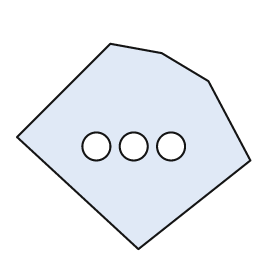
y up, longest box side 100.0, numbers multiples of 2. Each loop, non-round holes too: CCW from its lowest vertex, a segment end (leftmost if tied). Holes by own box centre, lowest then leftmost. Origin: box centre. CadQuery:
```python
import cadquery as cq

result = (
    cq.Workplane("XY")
    .moveTo(2.0, -44.0)
    .lineTo(50.0, -6.0)
    .lineTo(32.0, 28.0)
    .lineTo(12.0, 40.0)
    .lineTo(-10.0, 44.0)
    .lineTo(-50.0, 4.0)
    .close()
    .moveTo(-16.0, 0.0)
    .circle(6.0)
    .moveTo(0.0, 0.0)
    .circle(6.0)
    .moveTo(16.0, 0.0)
    .circle(6.0)
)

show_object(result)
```